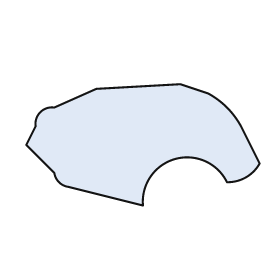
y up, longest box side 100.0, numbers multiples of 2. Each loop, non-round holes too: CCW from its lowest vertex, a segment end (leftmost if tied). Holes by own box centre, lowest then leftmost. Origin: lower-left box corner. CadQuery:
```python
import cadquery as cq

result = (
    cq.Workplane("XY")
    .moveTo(50.0, 0.0)
    .threePointArc((64.0, 20.0), (86.0, 10.0))
    .threePointArc((94.0, 12.0), (100.0, 18.0))
    .lineTo(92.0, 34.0)
    .threePointArc((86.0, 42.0), (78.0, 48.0))
    .lineTo(66.0, 52.0)
    .lineTo(30.0, 50.0)
    .lineTo(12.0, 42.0)
    .threePointArc((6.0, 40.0), (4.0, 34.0))
    .lineTo(0.0, 26.0)
    .lineTo(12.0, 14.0)
    .threePointArc((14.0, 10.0), (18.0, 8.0))
    .close()
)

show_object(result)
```